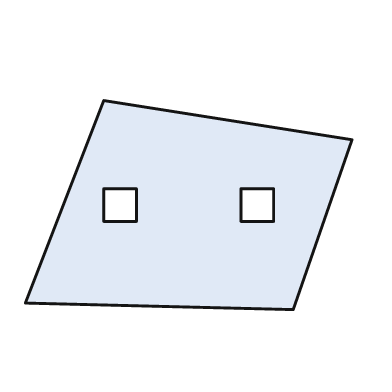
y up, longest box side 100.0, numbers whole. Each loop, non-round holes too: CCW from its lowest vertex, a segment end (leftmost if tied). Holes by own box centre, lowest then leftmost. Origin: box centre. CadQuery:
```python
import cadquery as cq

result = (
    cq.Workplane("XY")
    .moveTo(32.0, -32.0)
    .lineTo(50.0, 20.0)
    .lineTo(-26.0, 32.0)
    .lineTo(-50.0, -30.0)
    .close()
    .moveTo(-26.0, -5.0)
    .lineTo(-16.0, -5.0)
    .lineTo(-16.0, 5.0)
    .lineTo(-26.0, 5.0)
    .close()
    .moveTo(16.0, -5.0)
    .lineTo(26.0, -5.0)
    .lineTo(26.0, 5.0)
    .lineTo(16.0, 5.0)
    .close()
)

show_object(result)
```